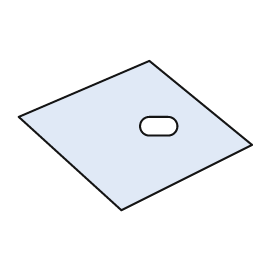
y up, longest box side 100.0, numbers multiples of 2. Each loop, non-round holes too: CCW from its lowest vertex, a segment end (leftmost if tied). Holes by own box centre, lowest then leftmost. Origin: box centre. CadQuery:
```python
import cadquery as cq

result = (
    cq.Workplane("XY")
    .moveTo(-6.0, -32.0)
    .lineTo(50.0, -4.0)
    .lineTo(6.0, 32.0)
    .lineTo(-50.0, 8.0)
    .close()
    .moveTo(6.0, 0.0)
    .lineTo(14.0, 0.0)
    .threePointArc((18.0, 4.0), (14.0, 8.0))
    .lineTo(6.0, 8.0)
    .threePointArc((2.0, 4.0), (6.0, 0.0))
    .close()
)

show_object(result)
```